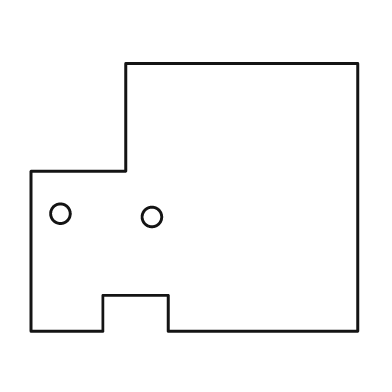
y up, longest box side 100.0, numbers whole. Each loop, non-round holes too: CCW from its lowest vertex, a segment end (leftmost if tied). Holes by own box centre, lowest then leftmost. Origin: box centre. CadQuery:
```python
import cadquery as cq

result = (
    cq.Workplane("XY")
    .moveTo(-50.0, -41.0)
    .lineTo(-28.0, -41.0)
    .lineTo(-28.0, -30.0)
    .lineTo(-8.0, -30.0)
    .lineTo(-8.0, -41.0)
    .lineTo(50.0, -41.0)
    .lineTo(50.0, 41.0)
    .lineTo(-21.0, 41.0)
    .lineTo(-21.0, 8.0)
    .lineTo(-50.0, 8.0)
    .close()
    .moveTo(-13.0, -6.0)
    .circle(3.0)
    .moveTo(-41.0, -5.0)
    .circle(3.0)
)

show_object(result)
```